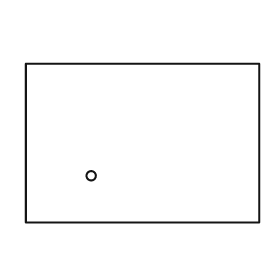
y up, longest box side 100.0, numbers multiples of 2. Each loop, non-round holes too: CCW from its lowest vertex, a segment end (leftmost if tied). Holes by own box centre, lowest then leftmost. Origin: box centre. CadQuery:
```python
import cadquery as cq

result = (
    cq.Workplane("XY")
    .moveTo(-50.0, -34.0)
    .lineTo(50.0, -34.0)
    .lineTo(50.0, 34.0)
    .lineTo(-50.0, 34.0)
    .close()
    .moveTo(-22.0, -14.0)
    .circle(2.0)
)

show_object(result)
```